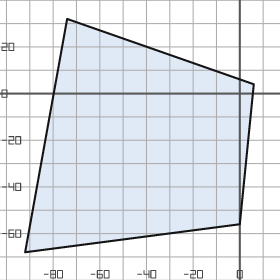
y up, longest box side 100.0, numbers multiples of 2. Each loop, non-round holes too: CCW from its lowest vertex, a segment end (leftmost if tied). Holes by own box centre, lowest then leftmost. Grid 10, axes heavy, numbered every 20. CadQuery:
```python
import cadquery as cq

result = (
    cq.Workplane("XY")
    .moveTo(-92.0, -68.0)
    .lineTo(0.0, -56.0)
    .lineTo(6.0, 4.0)
    .lineTo(-74.0, 32.0)
    .close()
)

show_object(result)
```